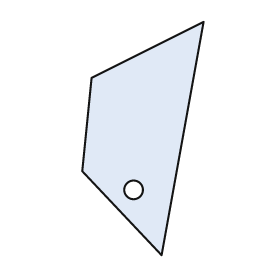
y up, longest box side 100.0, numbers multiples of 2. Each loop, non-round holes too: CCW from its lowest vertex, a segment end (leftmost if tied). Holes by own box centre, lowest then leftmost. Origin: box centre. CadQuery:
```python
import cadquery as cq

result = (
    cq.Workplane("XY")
    .moveTo(8.0, -50.0)
    .lineTo(26.0, 50.0)
    .lineTo(-22.0, 26.0)
    .lineTo(-26.0, -14.0)
    .close()
    .moveTo(-4.0, -22.0)
    .circle(4.0)
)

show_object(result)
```